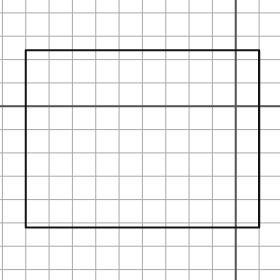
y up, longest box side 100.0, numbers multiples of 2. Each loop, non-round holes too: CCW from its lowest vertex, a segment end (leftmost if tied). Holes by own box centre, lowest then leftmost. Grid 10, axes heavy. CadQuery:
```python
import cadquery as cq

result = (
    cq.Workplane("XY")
    .moveTo(-90.0, -52.0)
    .lineTo(10.0, -52.0)
    .lineTo(10.0, 24.0)
    .lineTo(-90.0, 24.0)
    .close()
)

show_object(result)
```